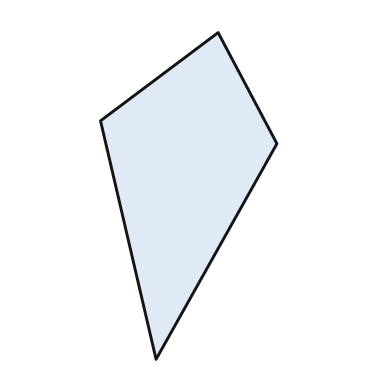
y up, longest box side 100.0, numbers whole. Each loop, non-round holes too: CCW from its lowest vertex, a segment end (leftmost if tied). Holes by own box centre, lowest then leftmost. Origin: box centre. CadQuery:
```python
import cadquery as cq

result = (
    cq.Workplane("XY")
    .moveTo(-10.0, -50.0)
    .lineTo(27.0, 16.0)
    .lineTo(9.0, 50.0)
    .lineTo(-27.0, 23.0)
    .close()
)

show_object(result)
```